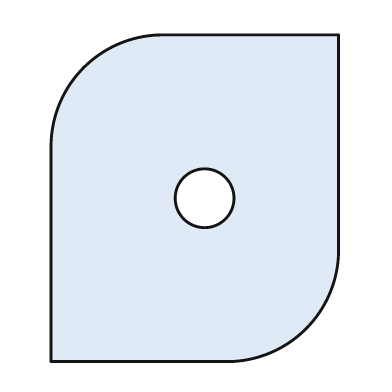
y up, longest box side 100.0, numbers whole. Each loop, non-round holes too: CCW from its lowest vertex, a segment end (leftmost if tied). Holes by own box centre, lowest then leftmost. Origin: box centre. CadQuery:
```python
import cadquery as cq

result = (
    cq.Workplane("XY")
    .moveTo(-44.0, -50.0)
    .lineTo(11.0, -50.0)
    .threePointArc((34.0, -40.0), (44.0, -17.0))
    .lineTo(44.0, 50.0)
    .lineTo(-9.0, 50.0)
    .threePointArc((-34.0, 40.0), (-44.0, 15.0))
    .close()
    .moveTo(3.0, 0.0)
    .circle(9.0)
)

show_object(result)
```